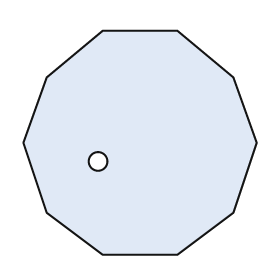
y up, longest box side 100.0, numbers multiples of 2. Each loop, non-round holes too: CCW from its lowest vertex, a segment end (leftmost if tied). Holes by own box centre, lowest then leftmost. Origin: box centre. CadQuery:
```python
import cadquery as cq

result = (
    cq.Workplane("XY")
    .moveTo(-16.0, -48.0)
    .lineTo(16.0, -48.0)
    .lineTo(40.0, -30.0)
    .lineTo(50.0, 0.0)
    .lineTo(40.0, 28.0)
    .lineTo(16.0, 48.0)
    .lineTo(-16.0, 48.0)
    .lineTo(-40.0, 28.0)
    .lineTo(-50.0, 0.0)
    .lineTo(-40.0, -30.0)
    .close()
    .moveTo(-18.0, -8.0)
    .circle(4.0)
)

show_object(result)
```